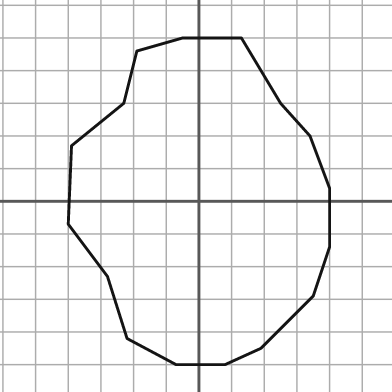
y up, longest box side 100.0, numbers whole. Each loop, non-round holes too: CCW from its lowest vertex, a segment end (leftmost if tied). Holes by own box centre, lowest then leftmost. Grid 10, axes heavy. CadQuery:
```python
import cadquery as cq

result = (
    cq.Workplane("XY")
    .moveTo(-7.0, -50.0)
    .lineTo(8.0, -50.0)
    .lineTo(19.0, -45.0)
    .lineTo(35.0, -29.0)
    .lineTo(40.0, -14.0)
    .lineTo(40.0, 4.0)
    .lineTo(34.0, 20.0)
    .lineTo(25.0, 30.0)
    .lineTo(13.0, 50.0)
    .lineTo(-5.0, 50.0)
    .lineTo(-19.0, 46.0)
    .lineTo(-23.0, 30.0)
    .lineTo(-39.0, 17.0)
    .lineTo(-40.0, -7.0)
    .lineTo(-28.0, -23.0)
    .lineTo(-22.0, -42.0)
    .close()
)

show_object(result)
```